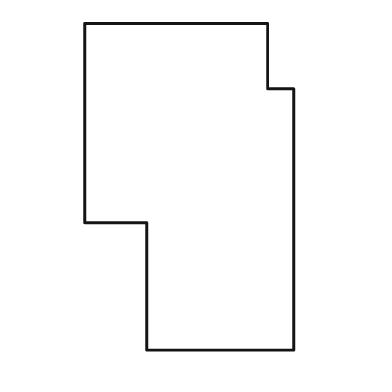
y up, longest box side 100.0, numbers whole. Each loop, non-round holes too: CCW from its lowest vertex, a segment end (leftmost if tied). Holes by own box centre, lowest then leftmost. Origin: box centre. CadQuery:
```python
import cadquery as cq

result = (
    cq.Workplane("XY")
    .moveTo(-13.0, -50.0)
    .lineTo(32.0, -50.0)
    .lineTo(32.0, 30.0)
    .lineTo(24.0, 30.0)
    .lineTo(24.0, 50.0)
    .lineTo(-32.0, 50.0)
    .lineTo(-32.0, -11.0)
    .lineTo(-13.0, -11.0)
    .close()
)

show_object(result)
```